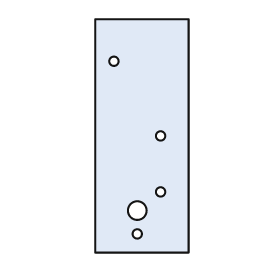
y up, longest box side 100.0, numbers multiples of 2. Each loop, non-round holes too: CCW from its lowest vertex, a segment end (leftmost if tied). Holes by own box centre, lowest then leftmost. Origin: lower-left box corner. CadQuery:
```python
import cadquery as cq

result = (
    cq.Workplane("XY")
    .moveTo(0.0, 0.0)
    .lineTo(40.0, 0.0)
    .lineTo(40.0, 100.0)
    .lineTo(0.0, 100.0)
    .close()
    .moveTo(18.0, 8.0)
    .circle(2.0)
    .moveTo(18.0, 18.0)
    .circle(4.0)
    .moveTo(28.0, 26.0)
    .circle(2.0)
    .moveTo(28.0, 50.0)
    .circle(2.0)
    .moveTo(8.0, 82.0)
    .circle(2.0)
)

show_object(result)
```